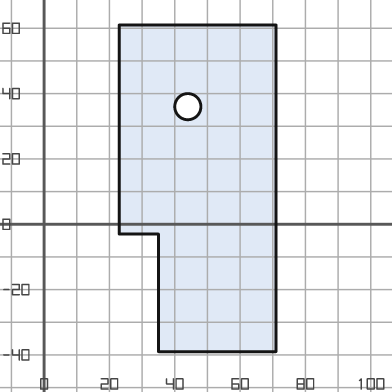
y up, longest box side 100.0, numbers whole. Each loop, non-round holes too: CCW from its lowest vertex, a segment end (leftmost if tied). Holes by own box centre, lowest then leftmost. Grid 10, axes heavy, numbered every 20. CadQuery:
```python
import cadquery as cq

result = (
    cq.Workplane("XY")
    .moveTo(35.0, -39.0)
    .lineTo(71.0, -39.0)
    .lineTo(71.0, 61.0)
    .lineTo(23.0, 61.0)
    .lineTo(23.0, -3.0)
    .lineTo(35.0, -3.0)
    .close()
    .moveTo(44.0, 36.0)
    .circle(4.0)
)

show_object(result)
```